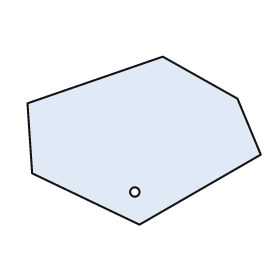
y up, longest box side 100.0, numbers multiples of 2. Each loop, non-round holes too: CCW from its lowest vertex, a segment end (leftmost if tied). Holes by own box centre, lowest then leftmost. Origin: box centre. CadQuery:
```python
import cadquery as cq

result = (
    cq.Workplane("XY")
    .moveTo(-2.0, -36.0)
    .lineTo(50.0, -6.0)
    .lineTo(40.0, 18.0)
    .lineTo(8.0, 36.0)
    .lineTo(-50.0, 16.0)
    .lineTo(-48.0, -14.0)
    .close()
    .moveTo(-4.0, -22.0)
    .circle(2.0)
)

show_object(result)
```